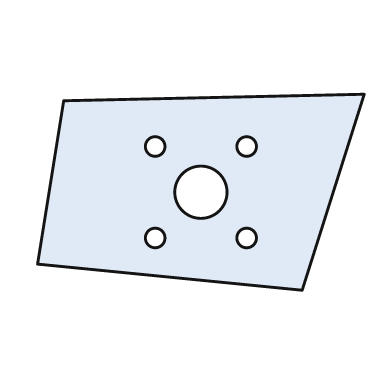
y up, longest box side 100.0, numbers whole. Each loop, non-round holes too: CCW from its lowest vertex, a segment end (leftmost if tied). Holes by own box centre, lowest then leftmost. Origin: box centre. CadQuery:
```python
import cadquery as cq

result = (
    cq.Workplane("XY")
    .moveTo(31.0, -30.0)
    .lineTo(50.0, 30.0)
    .lineTo(-42.0, 28.0)
    .lineTo(-50.0, -22.0)
    .close()
    .moveTo(-14.0, -14.0)
    .circle(3.0)
    .moveTo(14.0, -14.0)
    .circle(3.0)
    .moveTo(0.0, 0.0)
    .circle(8.0)
    .moveTo(-14.0, 14.0)
    .circle(3.0)
    .moveTo(14.0, 14.0)
    .circle(3.0)
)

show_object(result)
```